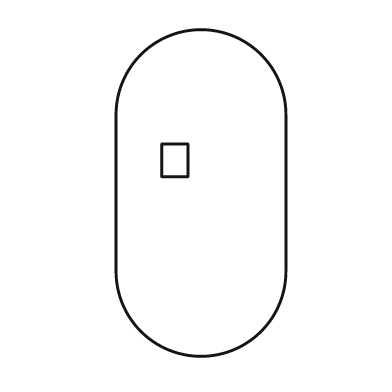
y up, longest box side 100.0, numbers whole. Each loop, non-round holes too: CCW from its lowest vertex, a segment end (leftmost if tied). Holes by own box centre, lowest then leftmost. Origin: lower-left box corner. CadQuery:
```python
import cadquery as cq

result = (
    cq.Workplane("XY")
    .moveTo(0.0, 26.0)
    .threePointArc((26.0, 0.0), (52.0, 26.0))
    .lineTo(52.0, 74.0)
    .threePointArc((26.0, 100.0), (0.0, 74.0))
    .close()
    .moveTo(14.0, 55.0)
    .lineTo(22.0, 55.0)
    .lineTo(22.0, 65.0)
    .lineTo(14.0, 65.0)
    .close()
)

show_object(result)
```